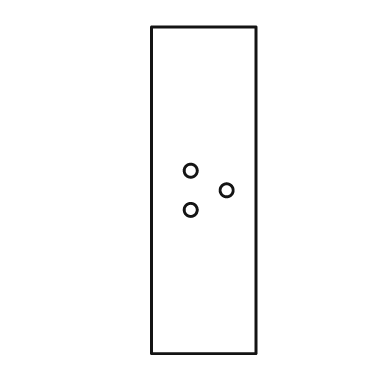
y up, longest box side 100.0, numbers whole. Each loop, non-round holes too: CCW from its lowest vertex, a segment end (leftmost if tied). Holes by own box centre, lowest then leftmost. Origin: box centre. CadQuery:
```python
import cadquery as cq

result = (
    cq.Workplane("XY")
    .moveTo(-16.0, -50.0)
    .lineTo(16.0, -50.0)
    .lineTo(16.0, 50.0)
    .lineTo(-16.0, 50.0)
    .close()
    .moveTo(-4.0, -6.0)
    .circle(2.0)
    .moveTo(7.0, 0.0)
    .circle(2.0)
    .moveTo(-4.0, 6.0)
    .circle(2.0)
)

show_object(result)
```